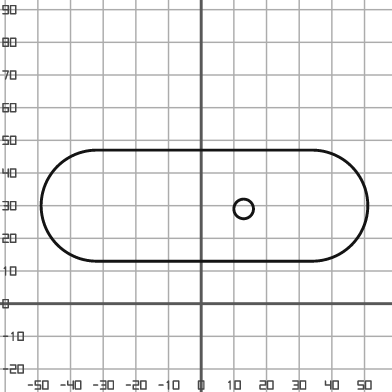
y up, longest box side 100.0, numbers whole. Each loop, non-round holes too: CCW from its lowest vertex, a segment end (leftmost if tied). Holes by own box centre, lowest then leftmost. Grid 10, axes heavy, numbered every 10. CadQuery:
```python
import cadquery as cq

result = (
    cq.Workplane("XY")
    .moveTo(-32.0, 13.0)
    .lineTo(34.0, 13.0)
    .threePointArc((51.0, 30.0), (34.0, 47.0))
    .lineTo(-32.0, 47.0)
    .threePointArc((-49.0, 30.0), (-32.0, 13.0))
    .close()
    .moveTo(13.0, 29.0)
    .circle(3.0)
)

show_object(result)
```